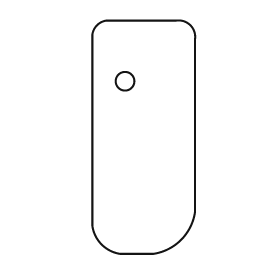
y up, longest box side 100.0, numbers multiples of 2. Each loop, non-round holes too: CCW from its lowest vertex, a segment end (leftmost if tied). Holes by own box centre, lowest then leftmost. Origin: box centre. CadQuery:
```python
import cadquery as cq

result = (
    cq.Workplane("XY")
    .moveTo(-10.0, -50.0)
    .lineTo(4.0, -50.0)
    .threePointArc((16.0, -44.0), (22.0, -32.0))
    .lineTo(22.0, 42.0)
    .threePointArc((20.0, 48.0), (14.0, 50.0))
    .lineTo(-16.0, 50.0)
    .threePointArc((-20.0, 48.0), (-22.0, 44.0))
    .lineTo(-22.0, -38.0)
    .threePointArc((-18.0, -46.0), (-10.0, -50.0))
    .close()
    .moveTo(-8.0, 24.0)
    .circle(4.0)
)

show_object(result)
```